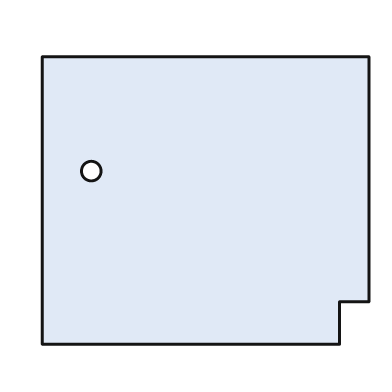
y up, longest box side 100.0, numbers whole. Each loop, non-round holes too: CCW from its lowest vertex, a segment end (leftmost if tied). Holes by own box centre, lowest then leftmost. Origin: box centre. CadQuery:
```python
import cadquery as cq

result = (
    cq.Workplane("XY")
    .moveTo(-50.0, -44.0)
    .lineTo(41.0, -44.0)
    .lineTo(41.0, -31.0)
    .lineTo(50.0, -31.0)
    .lineTo(50.0, 44.0)
    .lineTo(-50.0, 44.0)
    .close()
    .moveTo(-35.0, 9.0)
    .circle(3.0)
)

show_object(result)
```